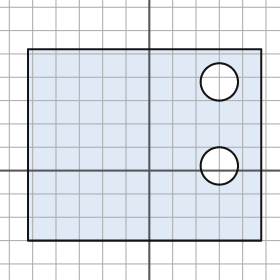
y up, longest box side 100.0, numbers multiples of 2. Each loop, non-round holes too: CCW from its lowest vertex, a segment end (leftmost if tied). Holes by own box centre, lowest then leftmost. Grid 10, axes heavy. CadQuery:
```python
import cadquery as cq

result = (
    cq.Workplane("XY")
    .moveTo(-52.0, -30.0)
    .lineTo(48.0, -30.0)
    .lineTo(48.0, 52.0)
    .lineTo(-52.0, 52.0)
    .close()
    .moveTo(30.0, 2.0)
    .circle(8.0)
    .moveTo(30.0, 38.0)
    .circle(8.0)
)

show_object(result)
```